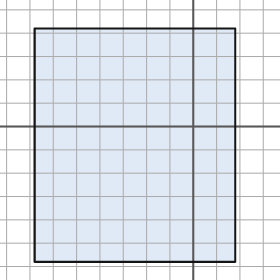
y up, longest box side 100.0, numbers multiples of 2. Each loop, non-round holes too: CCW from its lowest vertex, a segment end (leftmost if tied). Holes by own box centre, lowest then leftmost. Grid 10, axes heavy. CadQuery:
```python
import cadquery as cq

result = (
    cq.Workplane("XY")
    .moveTo(-68.0, -58.0)
    .lineTo(18.0, -58.0)
    .lineTo(18.0, 42.0)
    .lineTo(-68.0, 42.0)
    .close()
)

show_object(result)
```